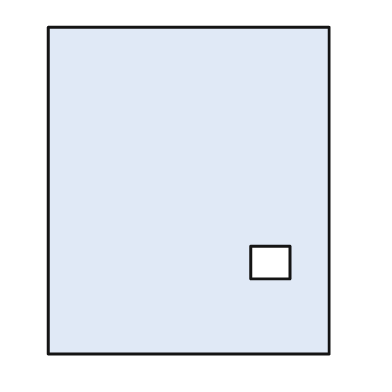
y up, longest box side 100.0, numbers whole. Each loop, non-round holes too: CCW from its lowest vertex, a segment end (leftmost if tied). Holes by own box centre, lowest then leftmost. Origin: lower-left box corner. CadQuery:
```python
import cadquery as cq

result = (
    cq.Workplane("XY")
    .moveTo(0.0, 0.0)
    .lineTo(86.0, 0.0)
    .lineTo(86.0, 100.0)
    .lineTo(0.0, 100.0)
    .close()
    .moveTo(62.0, 23.0)
    .lineTo(74.0, 23.0)
    .lineTo(74.0, 33.0)
    .lineTo(62.0, 33.0)
    .close()
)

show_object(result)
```